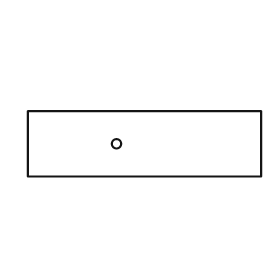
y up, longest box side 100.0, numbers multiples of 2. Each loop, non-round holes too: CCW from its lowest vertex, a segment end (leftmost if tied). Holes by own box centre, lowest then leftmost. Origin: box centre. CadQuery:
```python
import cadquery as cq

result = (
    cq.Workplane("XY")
    .moveTo(-50.0, -14.0)
    .lineTo(50.0, -14.0)
    .lineTo(50.0, 14.0)
    .lineTo(-50.0, 14.0)
    .close()
    .moveTo(-12.0, 0.0)
    .circle(2.0)
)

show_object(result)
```